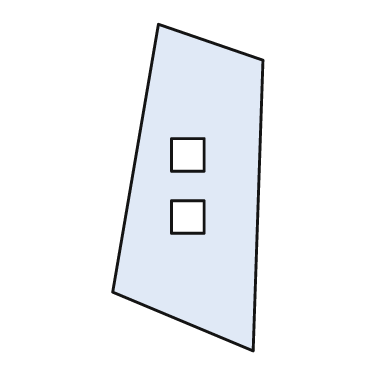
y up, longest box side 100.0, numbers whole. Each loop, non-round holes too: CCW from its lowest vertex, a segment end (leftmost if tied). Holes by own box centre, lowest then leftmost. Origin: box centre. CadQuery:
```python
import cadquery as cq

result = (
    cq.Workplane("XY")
    .moveTo(20.0, -50.0)
    .lineTo(23.0, 39.0)
    .lineTo(-9.0, 50.0)
    .lineTo(-23.0, -32.0)
    .close()
    .moveTo(-5.0, -14.0)
    .lineTo(5.0, -14.0)
    .lineTo(5.0, -4.0)
    .lineTo(-5.0, -4.0)
    .close()
    .moveTo(-5.0, 5.0)
    .lineTo(5.0, 5.0)
    .lineTo(5.0, 15.0)
    .lineTo(-5.0, 15.0)
    .close()
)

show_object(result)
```